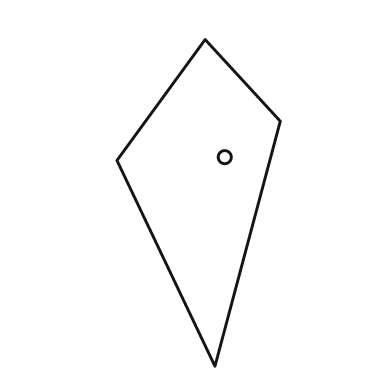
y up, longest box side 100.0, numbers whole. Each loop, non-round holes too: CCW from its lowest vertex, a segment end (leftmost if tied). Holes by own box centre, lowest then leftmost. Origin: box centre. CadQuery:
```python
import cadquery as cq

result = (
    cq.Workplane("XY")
    .moveTo(5.0, -50.0)
    .lineTo(25.0, 25.0)
    .lineTo(2.0, 50.0)
    .lineTo(-25.0, 13.0)
    .close()
    .moveTo(8.0, 14.0)
    .circle(2.0)
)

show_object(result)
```